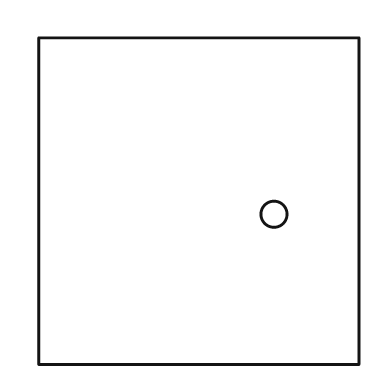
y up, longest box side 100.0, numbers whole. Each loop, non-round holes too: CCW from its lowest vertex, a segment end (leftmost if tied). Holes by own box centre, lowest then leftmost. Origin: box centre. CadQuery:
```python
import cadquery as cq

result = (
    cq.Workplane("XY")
    .moveTo(-49.0, -50.0)
    .lineTo(49.0, -50.0)
    .lineTo(49.0, 50.0)
    .lineTo(-49.0, 50.0)
    .close()
    .moveTo(23.0, -4.0)
    .circle(4.0)
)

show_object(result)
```